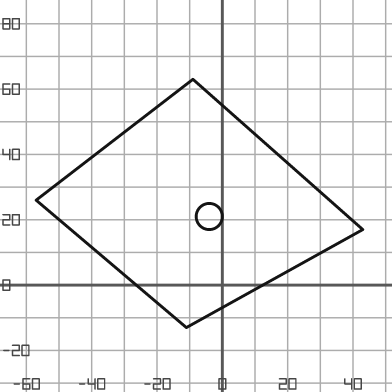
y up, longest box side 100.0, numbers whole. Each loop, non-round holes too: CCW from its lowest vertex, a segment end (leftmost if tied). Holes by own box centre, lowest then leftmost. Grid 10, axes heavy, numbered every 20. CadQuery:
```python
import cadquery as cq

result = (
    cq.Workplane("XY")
    .moveTo(-11.0, -13.0)
    .lineTo(43.0, 17.0)
    .lineTo(-9.0, 63.0)
    .lineTo(-57.0, 26.0)
    .close()
    .moveTo(-4.0, 21.0)
    .circle(4.0)
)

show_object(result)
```